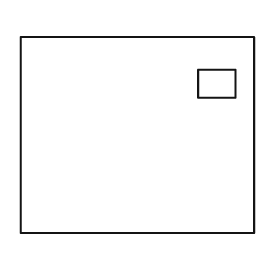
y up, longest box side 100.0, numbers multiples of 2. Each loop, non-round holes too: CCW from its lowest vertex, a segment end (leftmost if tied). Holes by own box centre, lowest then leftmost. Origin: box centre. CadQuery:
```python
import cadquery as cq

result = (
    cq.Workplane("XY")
    .moveTo(-50.0, -42.0)
    .lineTo(50.0, -42.0)
    .lineTo(50.0, 42.0)
    .lineTo(-50.0, 42.0)
    .close()
    .moveTo(26.0, 16.0)
    .lineTo(42.0, 16.0)
    .lineTo(42.0, 28.0)
    .lineTo(26.0, 28.0)
    .close()
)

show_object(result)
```